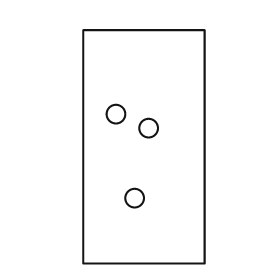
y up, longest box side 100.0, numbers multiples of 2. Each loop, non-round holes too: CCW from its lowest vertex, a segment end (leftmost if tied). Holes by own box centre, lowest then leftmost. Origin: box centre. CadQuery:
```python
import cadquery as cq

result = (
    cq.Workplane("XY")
    .moveTo(-26.0, -50.0)
    .lineTo(26.0, -50.0)
    .lineTo(26.0, 50.0)
    .lineTo(-26.0, 50.0)
    .close()
    .moveTo(-4.0, -22.0)
    .circle(4.0)
    .moveTo(2.0, 8.0)
    .circle(4.0)
    .moveTo(-12.0, 14.0)
    .circle(4.0)
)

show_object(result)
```